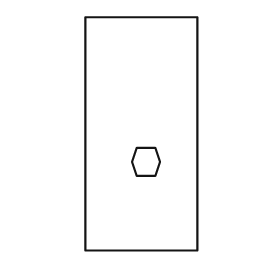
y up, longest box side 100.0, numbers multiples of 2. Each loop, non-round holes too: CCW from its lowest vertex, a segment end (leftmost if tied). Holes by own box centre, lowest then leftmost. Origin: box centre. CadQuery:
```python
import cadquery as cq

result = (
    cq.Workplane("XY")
    .moveTo(-24.0, -50.0)
    .lineTo(24.0, -50.0)
    .lineTo(24.0, 50.0)
    .lineTo(-24.0, 50.0)
    .close()
    .moveTo(-2.0, -18.0)
    .lineTo(6.0, -18.0)
    .lineTo(8.0, -12.0)
    .lineTo(6.0, -6.0)
    .lineTo(-2.0, -6.0)
    .lineTo(-4.0, -12.0)
    .close()
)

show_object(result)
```